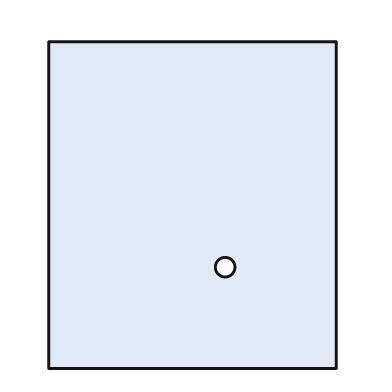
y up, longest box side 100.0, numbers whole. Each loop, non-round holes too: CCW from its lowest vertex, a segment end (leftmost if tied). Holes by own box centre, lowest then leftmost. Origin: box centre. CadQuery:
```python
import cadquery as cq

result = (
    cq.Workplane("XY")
    .moveTo(-44.0, -50.0)
    .lineTo(44.0, -50.0)
    .lineTo(44.0, 50.0)
    .lineTo(-44.0, 50.0)
    .close()
    .moveTo(10.0, -19.0)
    .circle(3.0)
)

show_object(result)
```